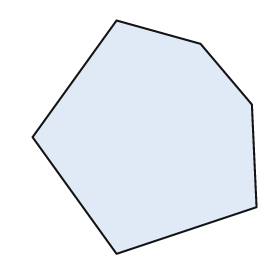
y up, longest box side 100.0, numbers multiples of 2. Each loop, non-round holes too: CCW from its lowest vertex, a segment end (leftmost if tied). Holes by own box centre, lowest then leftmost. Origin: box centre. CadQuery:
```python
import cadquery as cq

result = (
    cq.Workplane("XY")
    .moveTo(-12.0, -50.0)
    .lineTo(48.0, -30.0)
    .lineTo(46.0, 14.0)
    .lineTo(24.0, 40.0)
    .lineTo(-12.0, 50.0)
    .lineTo(-48.0, 0.0)
    .close()
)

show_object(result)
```